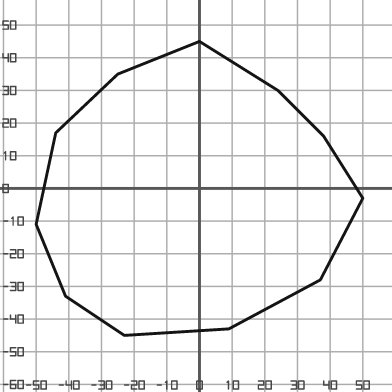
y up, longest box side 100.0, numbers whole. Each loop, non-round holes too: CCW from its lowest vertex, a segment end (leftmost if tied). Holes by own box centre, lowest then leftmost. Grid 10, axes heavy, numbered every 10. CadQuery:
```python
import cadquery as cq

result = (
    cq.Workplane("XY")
    .moveTo(-23.0, -45.0)
    .lineTo(9.0, -43.0)
    .lineTo(37.0, -28.0)
    .lineTo(50.0, -3.0)
    .lineTo(38.0, 16.0)
    .lineTo(24.0, 30.0)
    .lineTo(0.0, 45.0)
    .lineTo(-25.0, 35.0)
    .lineTo(-44.0, 17.0)
    .lineTo(-50.0, -11.0)
    .lineTo(-41.0, -33.0)
    .close()
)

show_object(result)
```